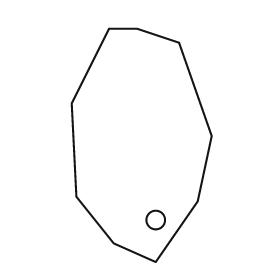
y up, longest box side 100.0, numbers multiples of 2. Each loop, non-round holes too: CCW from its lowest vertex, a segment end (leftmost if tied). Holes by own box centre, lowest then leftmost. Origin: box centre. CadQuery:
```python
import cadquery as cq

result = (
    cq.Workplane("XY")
    .moveTo(6.0, -50.0)
    .lineTo(24.0, -24.0)
    .lineTo(30.0, 4.0)
    .lineTo(16.0, 44.0)
    .lineTo(-2.0, 50.0)
    .lineTo(-14.0, 50.0)
    .lineTo(-30.0, 18.0)
    .lineTo(-28.0, -22.0)
    .lineTo(-12.0, -42.0)
    .close()
    .moveTo(6.0, -32.0)
    .circle(4.0)
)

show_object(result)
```